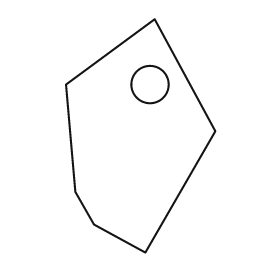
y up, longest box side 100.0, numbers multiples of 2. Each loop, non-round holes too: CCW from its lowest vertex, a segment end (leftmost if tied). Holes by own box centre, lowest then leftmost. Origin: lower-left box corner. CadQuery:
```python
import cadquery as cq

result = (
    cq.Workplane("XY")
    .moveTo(34.0, 0.0)
    .lineTo(64.0, 52.0)
    .lineTo(38.0, 100.0)
    .lineTo(0.0, 72.0)
    .lineTo(4.0, 26.0)
    .lineTo(12.0, 12.0)
    .close()
    .moveTo(36.0, 72.0)
    .circle(8.0)
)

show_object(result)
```